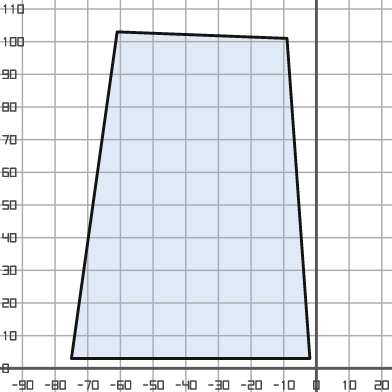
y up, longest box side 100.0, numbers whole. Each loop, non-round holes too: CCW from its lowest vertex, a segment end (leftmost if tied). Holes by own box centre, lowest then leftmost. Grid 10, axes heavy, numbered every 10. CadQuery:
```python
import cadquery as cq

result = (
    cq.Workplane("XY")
    .moveTo(-75.0, 3.0)
    .lineTo(-2.0, 3.0)
    .lineTo(-9.0, 101.0)
    .lineTo(-61.0, 103.0)
    .close()
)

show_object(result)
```